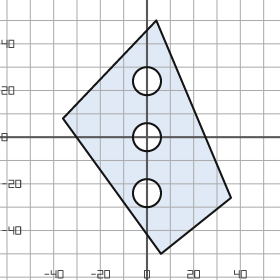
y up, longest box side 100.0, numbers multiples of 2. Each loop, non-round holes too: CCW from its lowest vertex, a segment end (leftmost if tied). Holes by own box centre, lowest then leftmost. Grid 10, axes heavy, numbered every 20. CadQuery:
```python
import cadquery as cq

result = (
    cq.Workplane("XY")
    .moveTo(6.0, -50.0)
    .lineTo(36.0, -26.0)
    .lineTo(4.0, 50.0)
    .lineTo(-36.0, 8.0)
    .close()
    .moveTo(0.0, -24.0)
    .circle(6.0)
    .moveTo(0.0, 0.0)
    .circle(6.0)
    .moveTo(0.0, 24.0)
    .circle(6.0)
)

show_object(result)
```